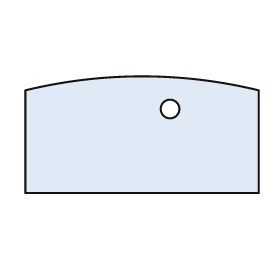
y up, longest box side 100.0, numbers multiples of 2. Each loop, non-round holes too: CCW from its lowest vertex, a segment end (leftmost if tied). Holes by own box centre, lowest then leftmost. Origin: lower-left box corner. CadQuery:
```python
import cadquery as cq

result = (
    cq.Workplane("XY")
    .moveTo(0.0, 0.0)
    .lineTo(100.0, 0.0)
    .lineTo(100.0, 44.0)
    .threePointArc((50.0, 50.0), (0.0, 44.0))
    .close()
    .moveTo(62.0, 36.0)
    .circle(4.0)
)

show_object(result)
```